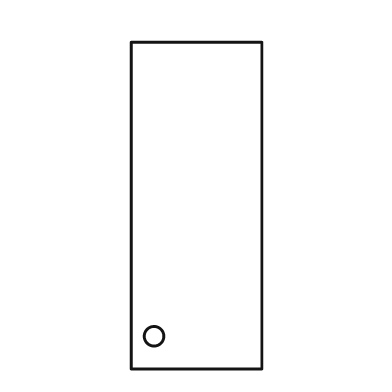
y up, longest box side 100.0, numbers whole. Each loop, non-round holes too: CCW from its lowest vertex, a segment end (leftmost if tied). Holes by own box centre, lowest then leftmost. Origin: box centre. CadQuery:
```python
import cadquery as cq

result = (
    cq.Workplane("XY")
    .moveTo(-20.0, -50.0)
    .lineTo(20.0, -50.0)
    .lineTo(20.0, 50.0)
    .lineTo(-20.0, 50.0)
    .close()
    .moveTo(-13.0, -40.0)
    .circle(3.0)
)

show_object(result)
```